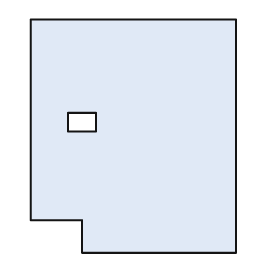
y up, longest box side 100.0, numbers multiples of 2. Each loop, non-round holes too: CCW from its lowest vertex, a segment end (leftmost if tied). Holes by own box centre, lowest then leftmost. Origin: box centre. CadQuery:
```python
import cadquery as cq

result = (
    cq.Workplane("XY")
    .moveTo(-22.0, -50.0)
    .lineTo(44.0, -50.0)
    .lineTo(44.0, 50.0)
    .lineTo(-44.0, 50.0)
    .lineTo(-44.0, -36.0)
    .lineTo(-22.0, -36.0)
    .close()
    .moveTo(-28.0, 2.0)
    .lineTo(-16.0, 2.0)
    .lineTo(-16.0, 10.0)
    .lineTo(-28.0, 10.0)
    .close()
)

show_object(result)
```